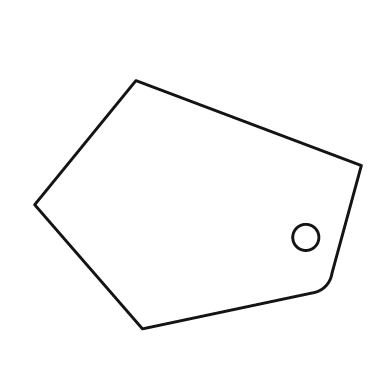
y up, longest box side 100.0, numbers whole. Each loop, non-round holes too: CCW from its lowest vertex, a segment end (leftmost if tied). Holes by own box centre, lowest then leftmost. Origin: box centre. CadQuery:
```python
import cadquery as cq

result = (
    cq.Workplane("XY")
    .moveTo(-17.0, -38.0)
    .lineTo(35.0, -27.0)
    .threePointArc((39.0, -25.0), (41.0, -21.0))
    .lineTo(50.0, 12.0)
    .lineTo(-19.0, 38.0)
    .lineTo(-50.0, 0.0)
    .close()
    .moveTo(33.0, -10.0)
    .circle(4.0)
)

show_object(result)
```